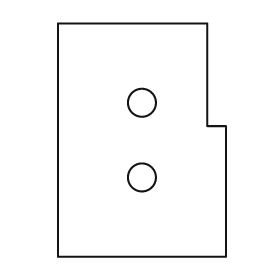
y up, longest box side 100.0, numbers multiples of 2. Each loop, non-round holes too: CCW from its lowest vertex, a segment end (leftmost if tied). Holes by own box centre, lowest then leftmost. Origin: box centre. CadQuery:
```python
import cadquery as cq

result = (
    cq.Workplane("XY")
    .moveTo(-36.0, -50.0)
    .lineTo(36.0, -50.0)
    .lineTo(36.0, 6.0)
    .lineTo(28.0, 6.0)
    .lineTo(28.0, 50.0)
    .lineTo(-36.0, 50.0)
    .close()
    .moveTo(0.0, -16.0)
    .circle(6.0)
    .moveTo(0.0, 16.0)
    .circle(6.0)
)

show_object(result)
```